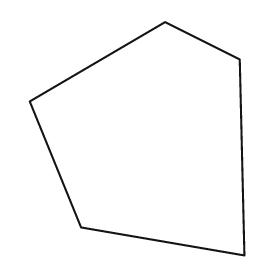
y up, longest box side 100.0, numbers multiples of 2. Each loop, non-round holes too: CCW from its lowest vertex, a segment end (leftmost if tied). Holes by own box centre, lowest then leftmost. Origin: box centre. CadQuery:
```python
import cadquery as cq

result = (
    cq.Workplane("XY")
    .moveTo(46.0, -50.0)
    .lineTo(44.0, 34.0)
    .lineTo(12.0, 50.0)
    .lineTo(-46.0, 16.0)
    .lineTo(-24.0, -38.0)
    .close()
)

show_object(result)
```